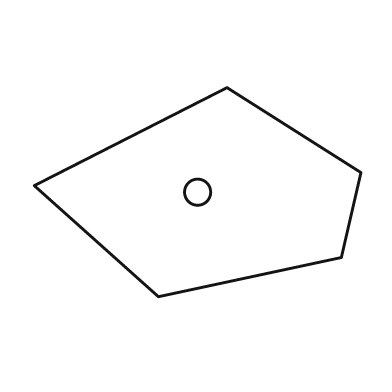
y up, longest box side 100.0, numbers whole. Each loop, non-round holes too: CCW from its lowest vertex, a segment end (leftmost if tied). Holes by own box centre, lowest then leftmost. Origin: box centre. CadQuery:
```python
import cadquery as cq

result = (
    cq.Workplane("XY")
    .moveTo(-12.0, -32.0)
    .lineTo(44.0, -20.0)
    .lineTo(50.0, 6.0)
    .lineTo(9.0, 32.0)
    .lineTo(-50.0, 2.0)
    .close()
    .moveTo(0.0, 0.0)
    .circle(4.0)
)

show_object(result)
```